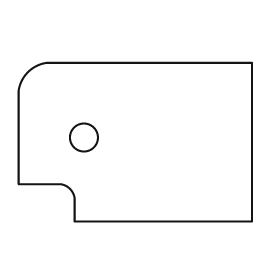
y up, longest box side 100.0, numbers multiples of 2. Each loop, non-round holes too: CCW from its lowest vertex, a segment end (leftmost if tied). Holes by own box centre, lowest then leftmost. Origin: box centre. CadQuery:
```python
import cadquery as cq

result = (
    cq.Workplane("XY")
    .moveTo(-26.0, -34.0)
    .lineTo(50.0, -34.0)
    .lineTo(50.0, 34.0)
    .lineTo(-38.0, 34.0)
    .threePointArc((-46.0, 30.0), (-50.0, 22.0))
    .lineTo(-50.0, -18.0)
    .lineTo(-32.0, -18.0)
    .threePointArc((-28.0, -20.0), (-26.0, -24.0))
    .close()
    .moveTo(-22.0, 2.0)
    .circle(6.0)
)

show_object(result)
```